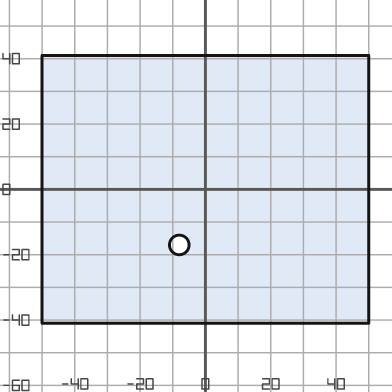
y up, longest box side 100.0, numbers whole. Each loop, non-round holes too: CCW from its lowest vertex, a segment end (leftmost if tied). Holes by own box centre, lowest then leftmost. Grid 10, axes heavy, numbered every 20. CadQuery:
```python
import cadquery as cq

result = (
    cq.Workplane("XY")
    .moveTo(-50.0, -41.0)
    .lineTo(50.0, -41.0)
    .lineTo(50.0, 41.0)
    .lineTo(-50.0, 41.0)
    .close()
    .moveTo(-8.0, -17.0)
    .circle(3.0)
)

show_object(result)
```